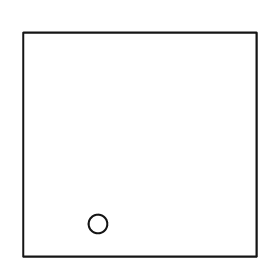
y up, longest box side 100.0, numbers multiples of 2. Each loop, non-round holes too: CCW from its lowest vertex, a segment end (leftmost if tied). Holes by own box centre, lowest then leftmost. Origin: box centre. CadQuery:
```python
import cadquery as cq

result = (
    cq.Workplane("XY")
    .moveTo(-50.0, -48.0)
    .lineTo(50.0, -48.0)
    .lineTo(50.0, 48.0)
    .lineTo(-50.0, 48.0)
    .close()
    .moveTo(-18.0, -34.0)
    .circle(4.0)
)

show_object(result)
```